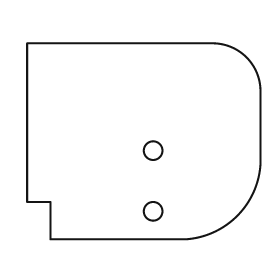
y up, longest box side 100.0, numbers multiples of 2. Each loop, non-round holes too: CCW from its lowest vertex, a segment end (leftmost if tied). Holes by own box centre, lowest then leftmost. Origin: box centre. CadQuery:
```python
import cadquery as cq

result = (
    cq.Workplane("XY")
    .moveTo(-40.0, -42.0)
    .lineTo(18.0, -42.0)
    .threePointArc((40.0, -32.0), (50.0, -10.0))
    .lineTo(50.0, 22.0)
    .threePointArc((44.0, 36.0), (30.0, 42.0))
    .lineTo(-50.0, 42.0)
    .lineTo(-50.0, -26.0)
    .lineTo(-40.0, -26.0)
    .close()
    .moveTo(4.0, -30.0)
    .circle(4.0)
    .moveTo(4.0, -4.0)
    .circle(4.0)
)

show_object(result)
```